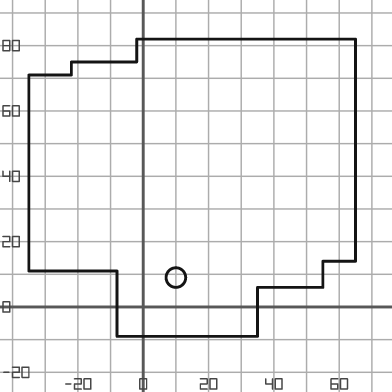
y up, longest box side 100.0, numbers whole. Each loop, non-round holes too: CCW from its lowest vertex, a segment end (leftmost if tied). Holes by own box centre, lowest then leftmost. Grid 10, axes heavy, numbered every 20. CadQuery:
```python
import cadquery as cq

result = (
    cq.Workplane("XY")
    .moveTo(-8.0, -9.0)
    .lineTo(35.0, -9.0)
    .lineTo(35.0, 6.0)
    .lineTo(55.0, 6.0)
    .lineTo(55.0, 14.0)
    .lineTo(65.0, 14.0)
    .lineTo(65.0, 82.0)
    .lineTo(-2.0, 82.0)
    .lineTo(-2.0, 75.0)
    .lineTo(-22.0, 75.0)
    .lineTo(-22.0, 71.0)
    .lineTo(-35.0, 71.0)
    .lineTo(-35.0, 11.0)
    .lineTo(-8.0, 11.0)
    .close()
    .moveTo(10.0, 9.0)
    .circle(3.0)
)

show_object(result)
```